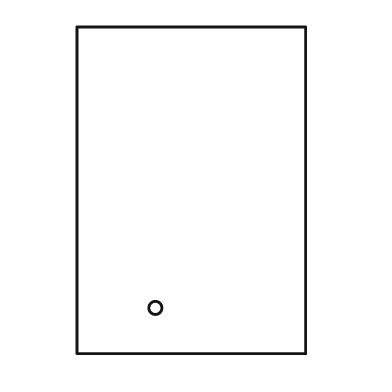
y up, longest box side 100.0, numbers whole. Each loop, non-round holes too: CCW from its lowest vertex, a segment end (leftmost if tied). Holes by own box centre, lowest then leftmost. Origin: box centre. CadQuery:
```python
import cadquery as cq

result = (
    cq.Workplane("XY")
    .moveTo(-35.0, -50.0)
    .lineTo(35.0, -50.0)
    .lineTo(35.0, 50.0)
    .lineTo(-35.0, 50.0)
    .close()
    .moveTo(-11.0, -36.0)
    .circle(2.0)
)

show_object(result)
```